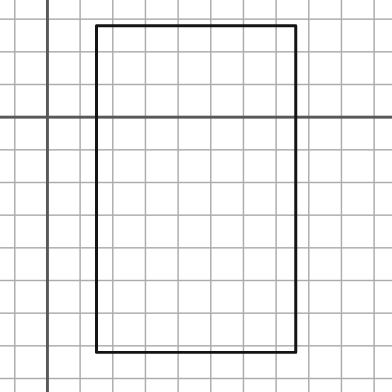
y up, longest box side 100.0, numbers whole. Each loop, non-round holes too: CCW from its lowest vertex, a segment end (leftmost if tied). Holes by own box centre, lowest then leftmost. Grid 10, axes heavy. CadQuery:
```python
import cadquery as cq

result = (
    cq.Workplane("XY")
    .moveTo(15.0, -72.0)
    .lineTo(76.0, -72.0)
    .lineTo(76.0, 28.0)
    .lineTo(15.0, 28.0)
    .close()
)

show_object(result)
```